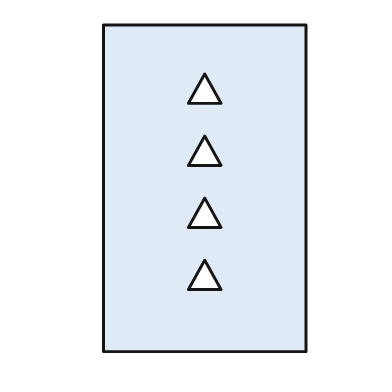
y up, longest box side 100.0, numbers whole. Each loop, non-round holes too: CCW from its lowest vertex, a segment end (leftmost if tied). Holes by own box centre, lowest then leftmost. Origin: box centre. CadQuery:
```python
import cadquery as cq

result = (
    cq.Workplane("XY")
    .moveTo(-31.0, -50.0)
    .lineTo(31.0, -50.0)
    .lineTo(31.0, 50.0)
    .lineTo(-31.0, 50.0)
    .close()
    .moveTo(-5.0, -31.0)
    .lineTo(5.0, -31.0)
    .lineTo(0.0, -22.0)
    .close()
    .moveTo(-5.0, -12.0)
    .lineTo(5.0, -12.0)
    .lineTo(0.0, -3.0)
    .close()
    .moveTo(-5.0, 7.0)
    .lineTo(5.0, 7.0)
    .lineTo(0.0, 16.0)
    .close()
    .moveTo(-5.0, 26.0)
    .lineTo(5.0, 26.0)
    .lineTo(0.0, 35.0)
    .close()
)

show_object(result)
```